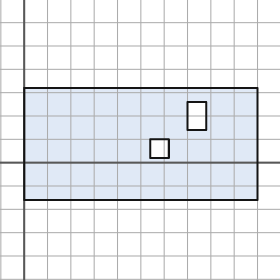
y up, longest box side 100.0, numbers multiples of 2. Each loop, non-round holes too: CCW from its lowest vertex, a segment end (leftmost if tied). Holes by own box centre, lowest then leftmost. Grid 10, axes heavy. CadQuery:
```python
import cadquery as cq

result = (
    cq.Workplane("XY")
    .moveTo(0.0, -16.0)
    .lineTo(100.0, -16.0)
    .lineTo(100.0, 32.0)
    .lineTo(0.0, 32.0)
    .close()
    .moveTo(54.0, 2.0)
    .lineTo(62.0, 2.0)
    .lineTo(62.0, 10.0)
    .lineTo(54.0, 10.0)
    .close()
    .moveTo(70.0, 14.0)
    .lineTo(78.0, 14.0)
    .lineTo(78.0, 26.0)
    .lineTo(70.0, 26.0)
    .close()
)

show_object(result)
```